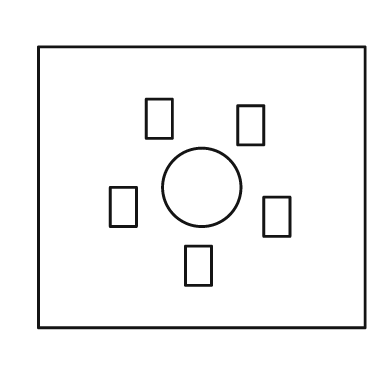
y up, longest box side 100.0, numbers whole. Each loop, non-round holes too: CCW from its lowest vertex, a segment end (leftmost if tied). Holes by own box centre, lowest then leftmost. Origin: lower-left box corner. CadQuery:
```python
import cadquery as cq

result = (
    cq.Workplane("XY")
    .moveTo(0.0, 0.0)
    .lineTo(100.0, 0.0)
    .lineTo(100.0, 86.0)
    .lineTo(0.0, 86.0)
    .close()
    .moveTo(45.0, 13.0)
    .lineTo(53.0, 13.0)
    .lineTo(53.0, 25.0)
    .lineTo(45.0, 25.0)
    .close()
    .moveTo(69.0, 28.0)
    .lineTo(77.0, 28.0)
    .lineTo(77.0, 40.0)
    .lineTo(69.0, 40.0)
    .close()
    .moveTo(22.0, 31.0)
    .lineTo(30.0, 31.0)
    .lineTo(30.0, 43.0)
    .lineTo(22.0, 43.0)
    .close()
    .moveTo(50.0, 43.0)
    .circle(12.0)
    .moveTo(61.0, 56.0)
    .lineTo(69.0, 56.0)
    .lineTo(69.0, 68.0)
    .lineTo(61.0, 68.0)
    .close()
    .moveTo(33.0, 58.0)
    .lineTo(41.0, 58.0)
    .lineTo(41.0, 70.0)
    .lineTo(33.0, 70.0)
    .close()
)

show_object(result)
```